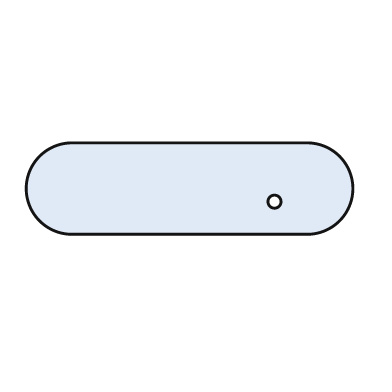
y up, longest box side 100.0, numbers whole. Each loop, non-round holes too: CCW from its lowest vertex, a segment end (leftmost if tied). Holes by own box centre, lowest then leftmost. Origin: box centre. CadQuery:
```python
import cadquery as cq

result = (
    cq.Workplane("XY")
    .moveTo(-36.0, -14.0)
    .lineTo(36.0, -14.0)
    .threePointArc((50.0, 0.0), (36.0, 14.0))
    .lineTo(-36.0, 14.0)
    .threePointArc((-50.0, 0.0), (-36.0, -14.0))
    .close()
    .moveTo(26.0, -4.0)
    .circle(2.0)
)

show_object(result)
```